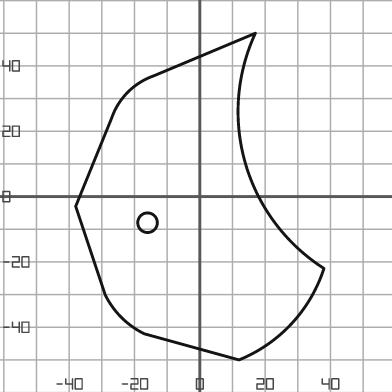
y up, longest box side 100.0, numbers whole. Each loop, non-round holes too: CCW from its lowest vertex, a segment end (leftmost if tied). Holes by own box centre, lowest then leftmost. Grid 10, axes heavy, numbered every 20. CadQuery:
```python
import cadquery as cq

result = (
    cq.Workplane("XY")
    .moveTo(12.0, -50.0)
    .threePointArc((28.0, -39.0), (38.0, -22.0))
    .threePointArc((14.0, 10.0), (17.0, 50.0))
    .lineTo(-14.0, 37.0)
    .threePointArc((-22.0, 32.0), (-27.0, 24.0))
    .lineTo(-38.0, -3.0)
    .lineTo(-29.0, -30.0)
    .threePointArc((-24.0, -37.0), (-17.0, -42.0))
    .close()
    .moveTo(-16.0, -8.0)
    .circle(3.0)
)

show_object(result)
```